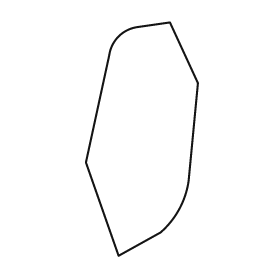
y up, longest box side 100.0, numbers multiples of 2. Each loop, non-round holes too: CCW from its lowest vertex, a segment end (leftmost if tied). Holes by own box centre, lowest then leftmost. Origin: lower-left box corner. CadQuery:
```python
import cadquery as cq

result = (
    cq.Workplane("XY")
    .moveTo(14.0, 0.0)
    .lineTo(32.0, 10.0)
    .threePointArc((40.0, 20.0), (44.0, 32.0))
    .lineTo(48.0, 74.0)
    .lineTo(36.0, 100.0)
    .lineTo(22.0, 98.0)
    .threePointArc((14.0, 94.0), (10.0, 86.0))
    .lineTo(0.0, 40.0)
    .close()
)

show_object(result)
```